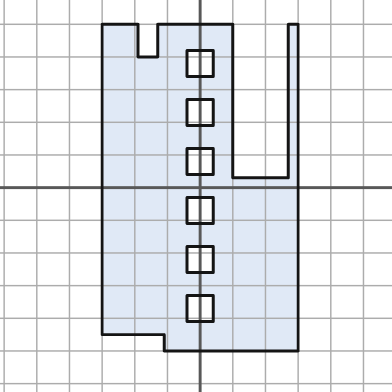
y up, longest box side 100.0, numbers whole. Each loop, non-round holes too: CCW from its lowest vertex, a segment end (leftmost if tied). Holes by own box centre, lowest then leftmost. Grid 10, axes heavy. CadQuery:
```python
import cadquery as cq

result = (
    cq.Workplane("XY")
    .moveTo(-11.0, -50.0)
    .lineTo(30.0, -50.0)
    .lineTo(30.0, 50.0)
    .lineTo(27.0, 50.0)
    .lineTo(27.0, 3.0)
    .lineTo(10.0, 3.0)
    .lineTo(10.0, 50.0)
    .lineTo(-13.0, 50.0)
    .lineTo(-13.0, 40.0)
    .lineTo(-19.0, 40.0)
    .lineTo(-19.0, 50.0)
    .lineTo(-30.0, 50.0)
    .lineTo(-30.0, -45.0)
    .lineTo(-11.0, -45.0)
    .close()
    .moveTo(-4.0, -41.0)
    .lineTo(4.0, -41.0)
    .lineTo(4.0, -33.0)
    .lineTo(-4.0, -33.0)
    .close()
    .moveTo(-4.0, -26.0)
    .lineTo(4.0, -26.0)
    .lineTo(4.0, -18.0)
    .lineTo(-4.0, -18.0)
    .close()
    .moveTo(-4.0, -11.0)
    .lineTo(4.0, -11.0)
    .lineTo(4.0, -3.0)
    .lineTo(-4.0, -3.0)
    .close()
    .moveTo(-4.0, 4.0)
    .lineTo(4.0, 4.0)
    .lineTo(4.0, 12.0)
    .lineTo(-4.0, 12.0)
    .close()
    .moveTo(-4.0, 19.0)
    .lineTo(4.0, 19.0)
    .lineTo(4.0, 27.0)
    .lineTo(-4.0, 27.0)
    .close()
    .moveTo(-4.0, 34.0)
    .lineTo(4.0, 34.0)
    .lineTo(4.0, 42.0)
    .lineTo(-4.0, 42.0)
    .close()
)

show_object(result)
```